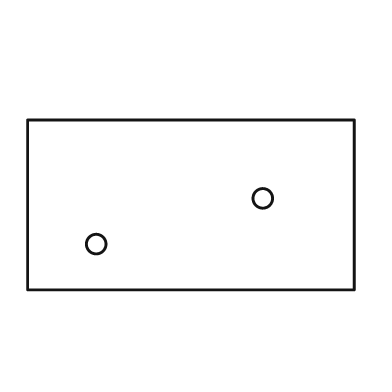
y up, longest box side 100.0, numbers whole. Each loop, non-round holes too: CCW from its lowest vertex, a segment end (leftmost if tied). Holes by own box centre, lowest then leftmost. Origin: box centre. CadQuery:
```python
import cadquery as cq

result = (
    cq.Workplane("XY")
    .moveTo(-50.0, -26.0)
    .lineTo(50.0, -26.0)
    .lineTo(50.0, 26.0)
    .lineTo(-50.0, 26.0)
    .close()
    .moveTo(-29.0, -12.0)
    .circle(3.0)
    .moveTo(22.0, 2.0)
    .circle(3.0)
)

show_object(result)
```